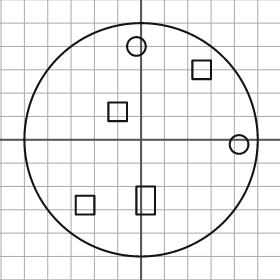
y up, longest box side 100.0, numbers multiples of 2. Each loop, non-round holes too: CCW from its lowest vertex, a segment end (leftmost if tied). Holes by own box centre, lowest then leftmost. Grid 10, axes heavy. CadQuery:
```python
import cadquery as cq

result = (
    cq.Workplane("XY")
    .moveTo(0.0, 0.0)
    .circle(50.0)
    .moveTo(-28.0, -32.0)
    .lineTo(-20.0, -32.0)
    .lineTo(-20.0, -24.0)
    .lineTo(-28.0, -24.0)
    .close()
    .moveTo(-2.0, -32.0)
    .lineTo(6.0, -32.0)
    .lineTo(6.0, -20.0)
    .lineTo(-2.0, -20.0)
    .close()
    .moveTo(42.0, -2.0)
    .circle(4.0)
    .moveTo(-14.0, 8.0)
    .lineTo(-6.0, 8.0)
    .lineTo(-6.0, 16.0)
    .lineTo(-14.0, 16.0)
    .close()
    .moveTo(22.0, 26.0)
    .lineTo(30.0, 26.0)
    .lineTo(30.0, 34.0)
    .lineTo(22.0, 34.0)
    .close()
    .moveTo(-2.0, 40.0)
    .circle(4.0)
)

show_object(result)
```